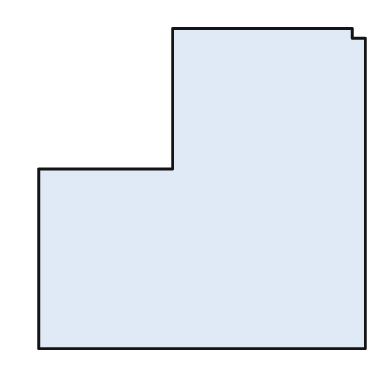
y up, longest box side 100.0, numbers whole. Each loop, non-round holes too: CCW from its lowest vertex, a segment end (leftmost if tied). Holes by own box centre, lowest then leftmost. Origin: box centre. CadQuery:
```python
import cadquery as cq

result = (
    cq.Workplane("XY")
    .moveTo(-50.0, -49.0)
    .lineTo(50.0, -49.0)
    .lineTo(50.0, 46.0)
    .lineTo(46.0, 46.0)
    .lineTo(46.0, 49.0)
    .lineTo(-9.0, 49.0)
    .lineTo(-9.0, 6.0)
    .lineTo(-50.0, 6.0)
    .close()
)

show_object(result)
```